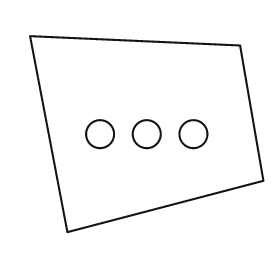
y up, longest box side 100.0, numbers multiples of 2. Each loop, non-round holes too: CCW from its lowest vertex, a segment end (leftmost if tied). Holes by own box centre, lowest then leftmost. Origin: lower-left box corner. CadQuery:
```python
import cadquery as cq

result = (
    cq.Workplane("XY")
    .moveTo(16.0, 0.0)
    .lineTo(100.0, 22.0)
    .lineTo(90.0, 80.0)
    .lineTo(0.0, 84.0)
    .close()
    .moveTo(30.0, 42.0)
    .circle(6.0)
    .moveTo(50.0, 42.0)
    .circle(6.0)
    .moveTo(70.0, 42.0)
    .circle(6.0)
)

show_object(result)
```